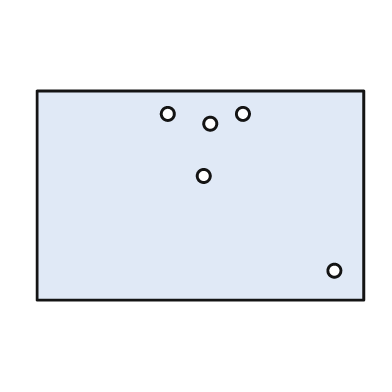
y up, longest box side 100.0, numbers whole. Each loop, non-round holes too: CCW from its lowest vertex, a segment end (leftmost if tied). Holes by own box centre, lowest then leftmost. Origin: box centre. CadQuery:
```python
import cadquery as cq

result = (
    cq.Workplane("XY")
    .moveTo(-50.0, -32.0)
    .lineTo(50.0, -32.0)
    .lineTo(50.0, 32.0)
    .lineTo(-50.0, 32.0)
    .close()
    .moveTo(41.0, -23.0)
    .circle(2.0)
    .moveTo(1.0, 6.0)
    .circle(2.0)
    .moveTo(3.0, 22.0)
    .circle(2.0)
    .moveTo(-10.0, 25.0)
    .circle(2.0)
    .moveTo(13.0, 25.0)
    .circle(2.0)
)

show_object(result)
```